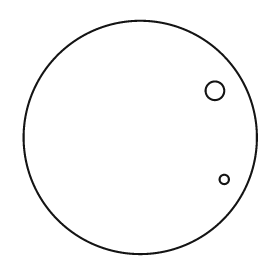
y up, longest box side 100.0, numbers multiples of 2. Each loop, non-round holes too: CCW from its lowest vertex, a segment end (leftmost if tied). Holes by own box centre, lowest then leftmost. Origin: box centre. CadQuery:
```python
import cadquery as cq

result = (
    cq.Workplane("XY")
    .moveTo(0.0, 0.0)
    .circle(50.0)
    .moveTo(36.0, -18.0)
    .circle(2.0)
    .moveTo(32.0, 20.0)
    .circle(4.0)
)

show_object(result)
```